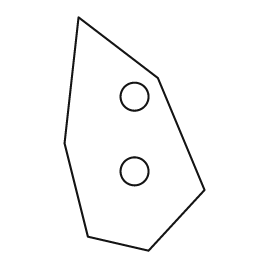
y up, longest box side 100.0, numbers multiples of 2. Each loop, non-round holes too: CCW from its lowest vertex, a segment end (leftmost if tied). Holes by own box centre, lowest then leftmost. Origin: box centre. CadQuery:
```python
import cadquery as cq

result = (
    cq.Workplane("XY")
    .moveTo(6.0, -50.0)
    .lineTo(30.0, -24.0)
    .lineTo(10.0, 24.0)
    .lineTo(-24.0, 50.0)
    .lineTo(-30.0, -4.0)
    .lineTo(-20.0, -44.0)
    .close()
    .moveTo(0.0, -16.0)
    .circle(6.0)
    .moveTo(0.0, 16.0)
    .circle(6.0)
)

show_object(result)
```